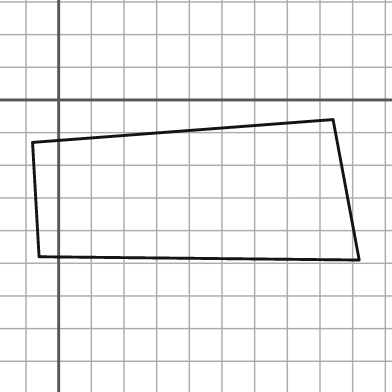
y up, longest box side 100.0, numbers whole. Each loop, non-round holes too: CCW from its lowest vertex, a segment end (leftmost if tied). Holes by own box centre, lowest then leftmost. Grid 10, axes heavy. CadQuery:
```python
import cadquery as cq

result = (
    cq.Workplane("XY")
    .moveTo(92.0, -49.0)
    .lineTo(84.0, -6.0)
    .lineTo(-8.0, -13.0)
    .lineTo(-6.0, -48.0)
    .close()
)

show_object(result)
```